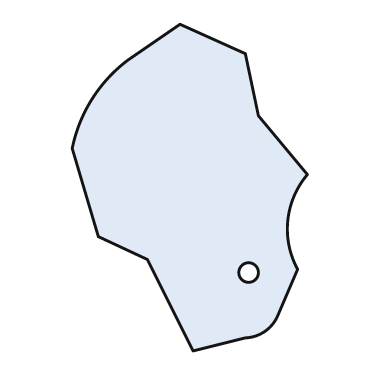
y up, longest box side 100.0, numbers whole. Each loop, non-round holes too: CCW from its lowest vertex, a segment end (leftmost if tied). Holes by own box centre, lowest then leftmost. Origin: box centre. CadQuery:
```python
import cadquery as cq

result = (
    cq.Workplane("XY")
    .moveTo(1.0, -50.0)
    .lineTo(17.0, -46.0)
    .threePointArc((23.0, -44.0), (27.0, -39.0))
    .lineTo(33.0, -25.0)
    .threePointArc((30.0, -10.0), (36.0, 4.0))
    .lineTo(21.0, 22.0)
    .lineTo(17.0, 41.0)
    .lineTo(-3.0, 50.0)
    .lineTo(-19.0, 39.0)
    .threePointArc((-30.0, 27.0), (-36.0, 12.0))
    .lineTo(-28.0, -15.0)
    .lineTo(-13.0, -22.0)
    .close()
    .moveTo(18.0, -26.0)
    .circle(3.0)
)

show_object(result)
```